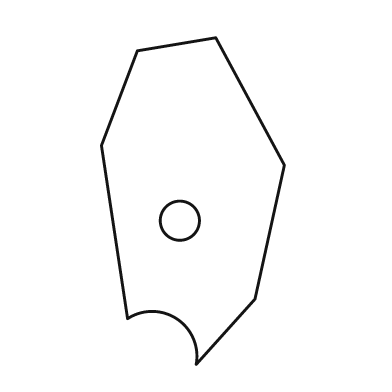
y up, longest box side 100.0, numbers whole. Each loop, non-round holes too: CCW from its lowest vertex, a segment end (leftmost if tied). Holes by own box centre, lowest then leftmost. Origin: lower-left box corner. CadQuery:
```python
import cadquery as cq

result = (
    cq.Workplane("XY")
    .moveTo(29.0, 0.0)
    .lineTo(47.0, 20.0)
    .lineTo(56.0, 61.0)
    .lineTo(35.0, 100.0)
    .lineTo(11.0, 96.0)
    .lineTo(0.0, 67.0)
    .lineTo(8.0, 14.0)
    .threePointArc((23.0, 14.0), (29.0, 0.0))
    .close()
    .moveTo(24.0, 44.0)
    .circle(6.0)
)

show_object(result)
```